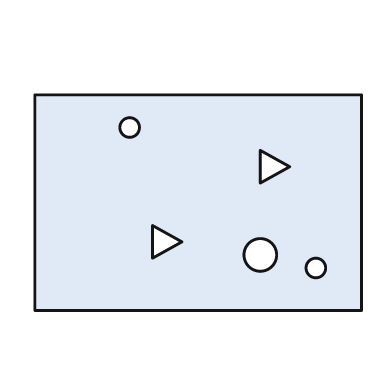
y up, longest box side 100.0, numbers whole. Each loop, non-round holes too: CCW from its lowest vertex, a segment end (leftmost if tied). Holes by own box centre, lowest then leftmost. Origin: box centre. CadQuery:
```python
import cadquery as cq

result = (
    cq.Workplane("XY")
    .moveTo(-50.0, -33.0)
    .lineTo(50.0, -33.0)
    .lineTo(50.0, 33.0)
    .lineTo(-50.0, 33.0)
    .close()
    .moveTo(36.0, -20.0)
    .circle(3.0)
    .moveTo(19.0, -16.0)
    .circle(5.0)
    .moveTo(-14.0, -17.0)
    .lineTo(-5.0, -12.0)
    .lineTo(-14.0, -7.0)
    .close()
    .moveTo(19.0, 6.0)
    .lineTo(28.0, 11.0)
    .lineTo(19.0, 16.0)
    .close()
    .moveTo(-21.0, 23.0)
    .circle(3.0)
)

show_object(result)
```